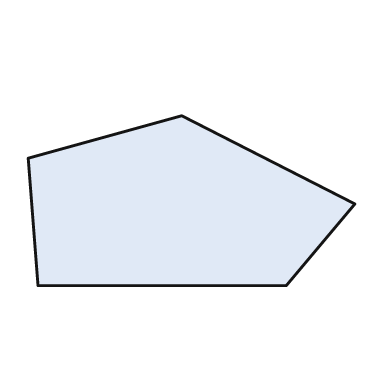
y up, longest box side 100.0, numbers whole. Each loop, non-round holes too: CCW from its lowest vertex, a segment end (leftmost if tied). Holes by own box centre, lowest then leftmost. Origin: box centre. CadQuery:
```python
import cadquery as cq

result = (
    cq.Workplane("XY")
    .moveTo(-47.0, -26.0)
    .lineTo(29.0, -26.0)
    .lineTo(50.0, -1.0)
    .lineTo(-3.0, 26.0)
    .lineTo(-50.0, 13.0)
    .close()
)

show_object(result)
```